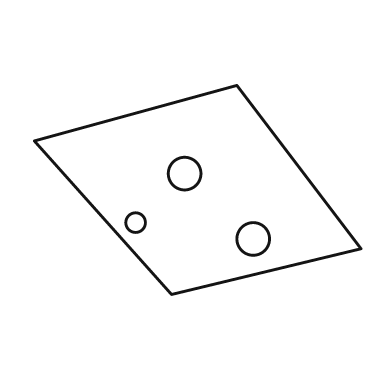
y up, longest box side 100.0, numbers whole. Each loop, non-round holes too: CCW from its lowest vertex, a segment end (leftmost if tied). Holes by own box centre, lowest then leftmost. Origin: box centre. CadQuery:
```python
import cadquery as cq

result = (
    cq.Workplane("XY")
    .moveTo(-8.0, -32.0)
    .lineTo(50.0, -18.0)
    .lineTo(12.0, 32.0)
    .lineTo(-50.0, 15.0)
    .close()
    .moveTo(17.0, -15.0)
    .circle(5.0)
    .moveTo(-19.0, -10.0)
    .circle(3.0)
    .moveTo(-4.0, 5.0)
    .circle(5.0)
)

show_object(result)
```